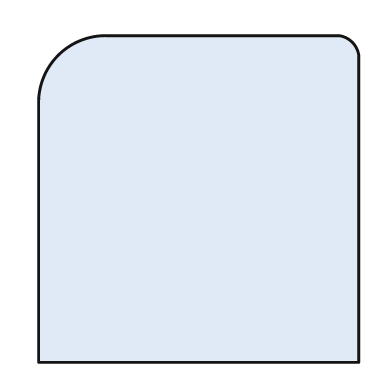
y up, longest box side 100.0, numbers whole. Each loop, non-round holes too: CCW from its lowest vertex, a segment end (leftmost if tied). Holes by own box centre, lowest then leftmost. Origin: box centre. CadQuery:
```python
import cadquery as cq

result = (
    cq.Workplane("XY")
    .moveTo(-49.0, -50.0)
    .lineTo(49.0, -50.0)
    .lineTo(49.0, 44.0)
    .threePointArc((47.0, 48.0), (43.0, 50.0))
    .lineTo(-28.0, 50.0)
    .threePointArc((-43.0, 44.0), (-49.0, 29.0))
    .close()
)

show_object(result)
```